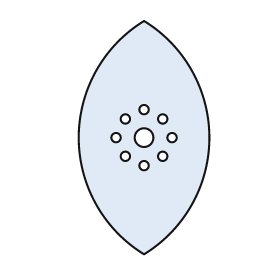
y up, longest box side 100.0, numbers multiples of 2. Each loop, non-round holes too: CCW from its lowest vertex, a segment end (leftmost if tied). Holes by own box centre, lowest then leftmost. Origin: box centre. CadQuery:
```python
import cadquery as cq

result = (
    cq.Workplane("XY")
    .moveTo(0.0, -50.0)
    .threePointArc((28.0, 0.0), (0.0, 50.0))
    .threePointArc((-28.0, 0.0), (0.0, -50.0))
    .close()
    .moveTo(0.0, -12.0)
    .circle(2.0)
    .moveTo(-8.0, -8.0)
    .circle(2.0)
    .moveTo(8.0, -8.0)
    .circle(2.0)
    .moveTo(-12.0, 0.0)
    .circle(2.0)
    .moveTo(0.0, 0.0)
    .circle(4.0)
    .moveTo(12.0, 0.0)
    .circle(2.0)
    .moveTo(-8.0, 8.0)
    .circle(2.0)
    .moveTo(8.0, 8.0)
    .circle(2.0)
    .moveTo(0.0, 12.0)
    .circle(2.0)
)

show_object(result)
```